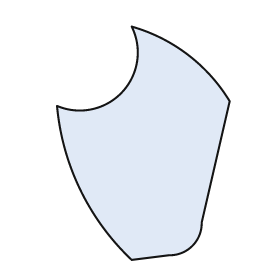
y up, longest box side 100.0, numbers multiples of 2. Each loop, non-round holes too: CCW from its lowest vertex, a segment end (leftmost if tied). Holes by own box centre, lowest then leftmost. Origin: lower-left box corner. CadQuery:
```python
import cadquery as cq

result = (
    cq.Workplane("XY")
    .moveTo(32.0, 0.0)
    .lineTo(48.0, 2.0)
    .threePointArc((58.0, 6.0), (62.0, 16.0))
    .lineTo(74.0, 68.0)
    .threePointArc((56.0, 88.0), (32.0, 100.0))
    .threePointArc((28.0, 72.0), (0.0, 66.0))
    .threePointArc((10.0, 30.0), (32.0, 0.0))
    .close()
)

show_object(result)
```